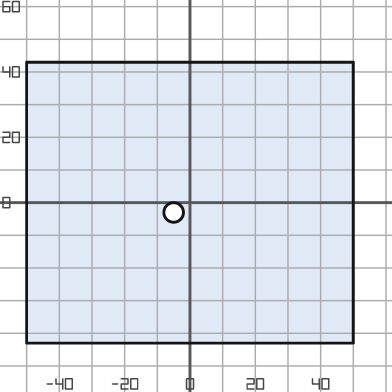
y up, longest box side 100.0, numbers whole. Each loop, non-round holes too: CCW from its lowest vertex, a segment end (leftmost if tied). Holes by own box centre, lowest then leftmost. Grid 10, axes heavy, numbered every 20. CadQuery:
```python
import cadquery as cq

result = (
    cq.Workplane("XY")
    .moveTo(-50.0, -43.0)
    .lineTo(50.0, -43.0)
    .lineTo(50.0, 43.0)
    .lineTo(-50.0, 43.0)
    .close()
    .moveTo(-5.0, -3.0)
    .circle(3.0)
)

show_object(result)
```